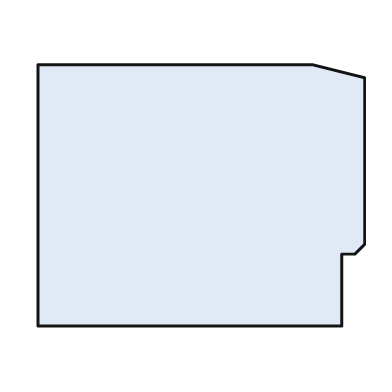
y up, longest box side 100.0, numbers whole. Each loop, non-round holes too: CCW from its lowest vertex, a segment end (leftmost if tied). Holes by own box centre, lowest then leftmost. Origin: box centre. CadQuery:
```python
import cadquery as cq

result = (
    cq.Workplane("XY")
    .moveTo(-50.0, -40.0)
    .lineTo(43.0, -40.0)
    .lineTo(43.0, -18.0)
    .lineTo(47.0, -18.0)
    .lineTo(50.0, -15.0)
    .lineTo(50.0, 36.0)
    .lineTo(34.0, 40.0)
    .lineTo(-50.0, 40.0)
    .close()
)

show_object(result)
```